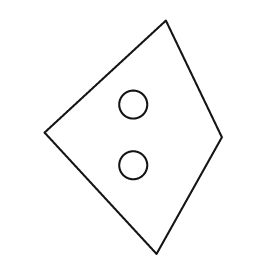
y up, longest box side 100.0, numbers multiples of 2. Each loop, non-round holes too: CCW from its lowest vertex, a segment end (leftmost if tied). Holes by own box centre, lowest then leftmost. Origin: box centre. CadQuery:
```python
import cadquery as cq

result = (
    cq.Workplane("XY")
    .moveTo(10.0, -50.0)
    .lineTo(38.0, 0.0)
    .lineTo(14.0, 50.0)
    .lineTo(-38.0, 2.0)
    .close()
    .moveTo(0.0, -12.0)
    .circle(6.0)
    .moveTo(0.0, 14.0)
    .circle(6.0)
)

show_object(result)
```